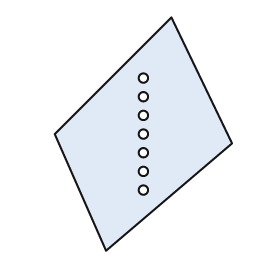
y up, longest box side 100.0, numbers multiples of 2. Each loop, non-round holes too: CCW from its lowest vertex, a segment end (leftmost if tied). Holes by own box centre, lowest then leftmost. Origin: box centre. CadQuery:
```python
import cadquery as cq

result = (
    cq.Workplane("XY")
    .moveTo(-16.0, -50.0)
    .lineTo(38.0, -4.0)
    .lineTo(12.0, 50.0)
    .lineTo(-38.0, 0.0)
    .close()
    .moveTo(0.0, -24.0)
    .circle(2.0)
    .moveTo(0.0, -16.0)
    .circle(2.0)
    .moveTo(0.0, -8.0)
    .circle(2.0)
    .moveTo(0.0, 0.0)
    .circle(2.0)
    .moveTo(0.0, 8.0)
    .circle(2.0)
    .moveTo(0.0, 16.0)
    .circle(2.0)
    .moveTo(0.0, 24.0)
    .circle(2.0)
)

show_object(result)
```